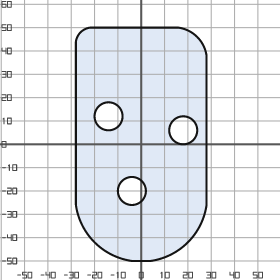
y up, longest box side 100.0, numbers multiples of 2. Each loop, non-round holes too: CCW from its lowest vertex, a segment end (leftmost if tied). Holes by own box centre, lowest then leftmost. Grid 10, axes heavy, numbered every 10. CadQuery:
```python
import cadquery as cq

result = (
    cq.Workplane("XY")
    .moveTo(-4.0, -50.0)
    .lineTo(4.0, -50.0)
    .threePointArc((20.0, -42.0), (28.0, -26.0))
    .lineTo(28.0, 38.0)
    .threePointArc((24.0, 46.0), (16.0, 50.0))
    .lineTo(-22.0, 50.0)
    .threePointArc((-26.0, 48.0), (-28.0, 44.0))
    .lineTo(-28.0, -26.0)
    .threePointArc((-20.0, -42.0), (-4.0, -50.0))
    .close()
    .moveTo(-4.0, -20.0)
    .circle(6.0)
    .moveTo(18.0, 6.0)
    .circle(6.0)
    .moveTo(-14.0, 12.0)
    .circle(6.0)
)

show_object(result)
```